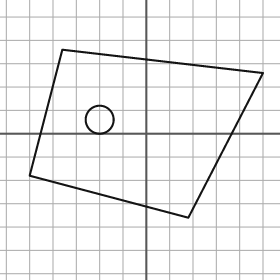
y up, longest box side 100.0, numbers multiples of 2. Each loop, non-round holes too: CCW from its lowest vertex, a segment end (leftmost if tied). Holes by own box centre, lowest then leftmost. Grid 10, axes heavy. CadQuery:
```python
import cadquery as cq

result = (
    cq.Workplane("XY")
    .moveTo(18.0, -36.0)
    .lineTo(50.0, 26.0)
    .lineTo(-36.0, 36.0)
    .lineTo(-50.0, -18.0)
    .close()
    .moveTo(-20.0, 6.0)
    .circle(6.0)
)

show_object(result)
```